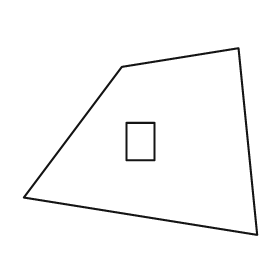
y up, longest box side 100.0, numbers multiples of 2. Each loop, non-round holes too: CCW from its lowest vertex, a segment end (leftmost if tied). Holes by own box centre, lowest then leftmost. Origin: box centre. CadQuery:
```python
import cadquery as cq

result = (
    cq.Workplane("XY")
    .moveTo(50.0, -40.0)
    .lineTo(42.0, 40.0)
    .lineTo(-8.0, 32.0)
    .lineTo(-50.0, -24.0)
    .close()
    .moveTo(-6.0, -8.0)
    .lineTo(6.0, -8.0)
    .lineTo(6.0, 8.0)
    .lineTo(-6.0, 8.0)
    .close()
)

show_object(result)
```